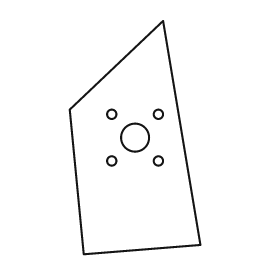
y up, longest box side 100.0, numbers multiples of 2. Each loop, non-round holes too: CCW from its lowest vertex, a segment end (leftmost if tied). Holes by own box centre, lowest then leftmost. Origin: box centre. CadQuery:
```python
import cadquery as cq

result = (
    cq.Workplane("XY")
    .moveTo(-22.0, -50.0)
    .lineTo(28.0, -46.0)
    .lineTo(12.0, 50.0)
    .lineTo(-28.0, 12.0)
    .close()
    .moveTo(-10.0, -10.0)
    .circle(2.0)
    .moveTo(10.0, -10.0)
    .circle(2.0)
    .moveTo(0.0, 0.0)
    .circle(6.0)
    .moveTo(-10.0, 10.0)
    .circle(2.0)
    .moveTo(10.0, 10.0)
    .circle(2.0)
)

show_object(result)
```